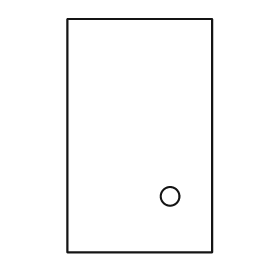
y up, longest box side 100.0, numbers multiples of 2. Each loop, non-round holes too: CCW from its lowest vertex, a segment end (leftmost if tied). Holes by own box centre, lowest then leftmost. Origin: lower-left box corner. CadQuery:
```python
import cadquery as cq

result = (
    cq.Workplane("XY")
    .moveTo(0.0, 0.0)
    .lineTo(62.0, 0.0)
    .lineTo(62.0, 100.0)
    .lineTo(0.0, 100.0)
    .close()
    .moveTo(44.0, 24.0)
    .circle(4.0)
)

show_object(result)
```